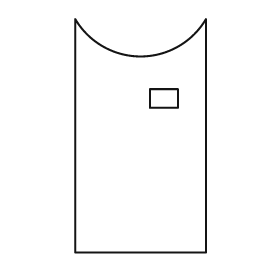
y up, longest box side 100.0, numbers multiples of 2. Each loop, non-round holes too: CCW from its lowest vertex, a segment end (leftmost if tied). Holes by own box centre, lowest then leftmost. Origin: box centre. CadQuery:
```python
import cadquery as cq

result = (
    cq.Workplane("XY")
    .moveTo(-28.0, -50.0)
    .lineTo(28.0, -50.0)
    .lineTo(28.0, 50.0)
    .threePointArc((0.0, 34.0), (-28.0, 50.0))
    .close()
    .moveTo(4.0, 12.0)
    .lineTo(16.0, 12.0)
    .lineTo(16.0, 20.0)
    .lineTo(4.0, 20.0)
    .close()
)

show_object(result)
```